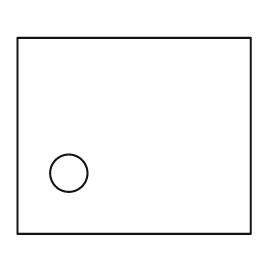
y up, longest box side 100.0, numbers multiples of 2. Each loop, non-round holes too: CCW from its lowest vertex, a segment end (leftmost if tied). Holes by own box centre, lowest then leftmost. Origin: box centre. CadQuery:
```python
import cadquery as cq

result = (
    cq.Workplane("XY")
    .moveTo(-50.0, -42.0)
    .lineTo(50.0, -42.0)
    .lineTo(50.0, 42.0)
    .lineTo(-50.0, 42.0)
    .close()
    .moveTo(-28.0, -16.0)
    .circle(8.0)
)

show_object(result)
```